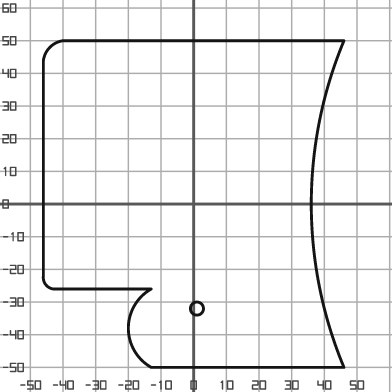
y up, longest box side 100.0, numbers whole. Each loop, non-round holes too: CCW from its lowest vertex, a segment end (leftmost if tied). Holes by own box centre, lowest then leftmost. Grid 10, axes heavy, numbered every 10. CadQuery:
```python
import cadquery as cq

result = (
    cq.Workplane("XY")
    .moveTo(-13.0, -50.0)
    .lineTo(46.0, -50.0)
    .threePointArc((36.0, 0.0), (46.0, 50.0))
    .lineTo(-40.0, 50.0)
    .threePointArc((-44.0, 48.0), (-46.0, 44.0))
    .lineTo(-46.0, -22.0)
    .threePointArc((-45.0, -25.0), (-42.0, -26.0))
    .lineTo(-13.0, -26.0)
    .threePointArc((-20.0, -38.0), (-13.0, -50.0))
    .close()
    .moveTo(1.0, -32.0)
    .circle(2.0)
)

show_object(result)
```